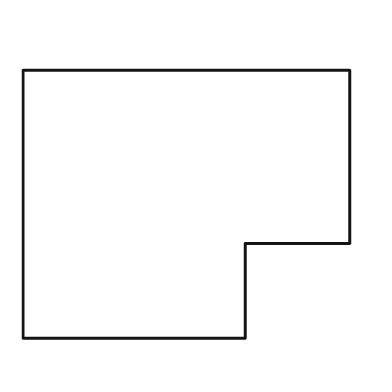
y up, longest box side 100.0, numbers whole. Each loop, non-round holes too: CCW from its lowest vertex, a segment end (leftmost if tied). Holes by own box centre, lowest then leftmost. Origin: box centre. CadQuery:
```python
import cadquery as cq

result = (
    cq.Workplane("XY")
    .moveTo(-50.0, -41.0)
    .lineTo(18.0, -41.0)
    .lineTo(18.0, -12.0)
    .lineTo(50.0, -12.0)
    .lineTo(50.0, 41.0)
    .lineTo(-50.0, 41.0)
    .close()
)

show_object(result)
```